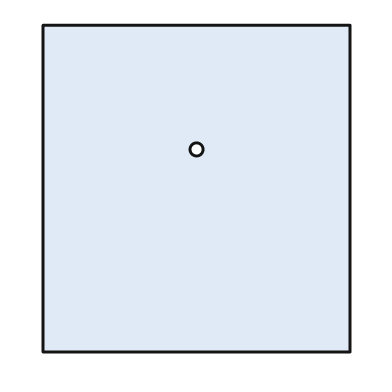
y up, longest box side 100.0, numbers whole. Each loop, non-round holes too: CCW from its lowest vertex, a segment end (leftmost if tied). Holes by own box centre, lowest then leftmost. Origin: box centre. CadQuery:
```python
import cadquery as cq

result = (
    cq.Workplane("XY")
    .moveTo(-47.0, -50.0)
    .lineTo(47.0, -50.0)
    .lineTo(47.0, 50.0)
    .lineTo(-47.0, 50.0)
    .close()
    .moveTo(0.0, 12.0)
    .circle(2.0)
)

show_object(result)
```